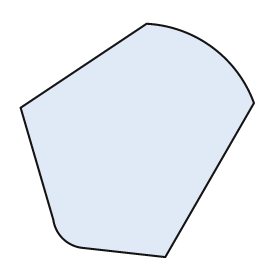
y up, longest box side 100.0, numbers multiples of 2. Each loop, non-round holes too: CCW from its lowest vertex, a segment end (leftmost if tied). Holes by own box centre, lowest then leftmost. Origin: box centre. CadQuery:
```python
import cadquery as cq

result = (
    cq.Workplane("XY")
    .moveTo(12.0, -50.0)
    .lineTo(50.0, 16.0)
    .threePointArc((32.0, 40.0), (4.0, 50.0))
    .lineTo(-50.0, 14.0)
    .lineTo(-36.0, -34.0)
    .threePointArc((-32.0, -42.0), (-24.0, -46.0))
    .close()
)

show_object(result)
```